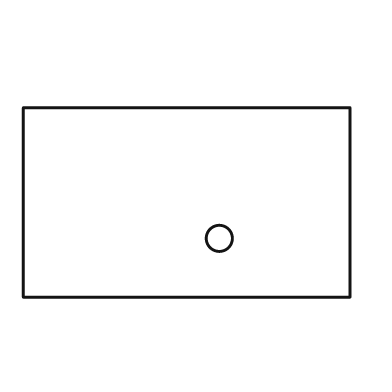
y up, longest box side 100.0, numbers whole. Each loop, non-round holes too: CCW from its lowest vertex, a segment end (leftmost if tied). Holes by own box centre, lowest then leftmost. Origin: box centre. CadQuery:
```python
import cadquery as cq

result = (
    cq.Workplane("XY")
    .moveTo(-50.0, -29.0)
    .lineTo(50.0, -29.0)
    .lineTo(50.0, 29.0)
    .lineTo(-50.0, 29.0)
    .close()
    .moveTo(10.0, -11.0)
    .circle(4.0)
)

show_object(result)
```